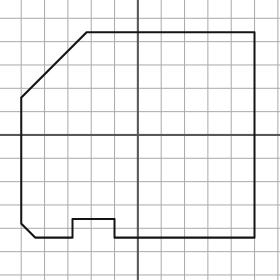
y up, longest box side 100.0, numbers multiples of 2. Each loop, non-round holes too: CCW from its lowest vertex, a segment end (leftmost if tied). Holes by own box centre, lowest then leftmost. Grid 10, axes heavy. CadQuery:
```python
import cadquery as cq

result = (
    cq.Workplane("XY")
    .moveTo(-44.0, -44.0)
    .lineTo(-28.0, -44.0)
    .lineTo(-28.0, -36.0)
    .lineTo(-10.0, -36.0)
    .lineTo(-10.0, -44.0)
    .lineTo(50.0, -44.0)
    .lineTo(50.0, 44.0)
    .lineTo(-22.0, 44.0)
    .lineTo(-50.0, 16.0)
    .lineTo(-50.0, -38.0)
    .close()
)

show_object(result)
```